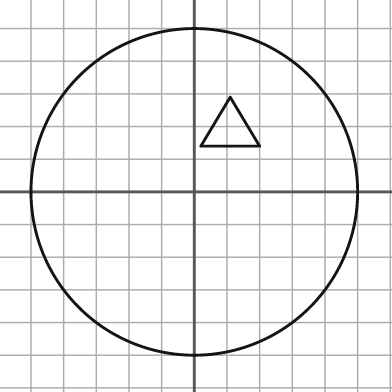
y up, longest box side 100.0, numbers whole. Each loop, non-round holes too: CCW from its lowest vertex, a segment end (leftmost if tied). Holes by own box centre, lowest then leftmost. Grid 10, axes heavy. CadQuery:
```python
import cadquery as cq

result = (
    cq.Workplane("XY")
    .moveTo(0.0, 0.0)
    .circle(50.0)
    .moveTo(2.0, 14.0)
    .lineTo(20.0, 14.0)
    .lineTo(11.0, 29.0)
    .close()
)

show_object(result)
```